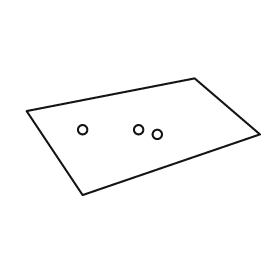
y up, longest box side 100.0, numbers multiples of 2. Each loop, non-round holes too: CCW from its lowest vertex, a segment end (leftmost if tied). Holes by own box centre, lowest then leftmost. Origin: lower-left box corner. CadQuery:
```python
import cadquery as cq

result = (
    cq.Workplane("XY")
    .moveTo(24.0, 0.0)
    .lineTo(100.0, 26.0)
    .lineTo(72.0, 50.0)
    .lineTo(0.0, 36.0)
    .close()
    .moveTo(56.0, 26.0)
    .circle(2.0)
    .moveTo(24.0, 28.0)
    .circle(2.0)
    .moveTo(48.0, 28.0)
    .circle(2.0)
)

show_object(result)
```